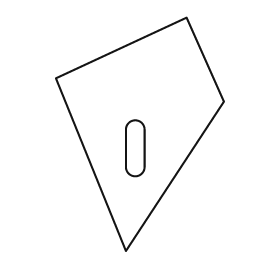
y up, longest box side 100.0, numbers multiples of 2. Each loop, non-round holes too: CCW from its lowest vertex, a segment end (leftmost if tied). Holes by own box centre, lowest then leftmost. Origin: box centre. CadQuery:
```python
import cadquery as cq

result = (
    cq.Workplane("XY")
    .moveTo(-6.0, -50.0)
    .lineTo(36.0, 14.0)
    .lineTo(20.0, 50.0)
    .lineTo(-36.0, 24.0)
    .close()
    .moveTo(-6.0, -14.0)
    .threePointArc((-2.0, -18.0), (2.0, -14.0))
    .lineTo(2.0, 2.0)
    .threePointArc((-2.0, 6.0), (-6.0, 2.0))
    .close()
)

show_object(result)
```